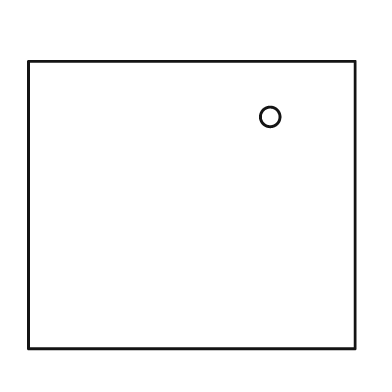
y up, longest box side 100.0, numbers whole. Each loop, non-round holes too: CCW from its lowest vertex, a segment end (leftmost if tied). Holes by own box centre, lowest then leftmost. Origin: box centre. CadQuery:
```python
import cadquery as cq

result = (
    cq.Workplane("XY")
    .moveTo(-50.0, -44.0)
    .lineTo(50.0, -44.0)
    .lineTo(50.0, 44.0)
    .lineTo(-50.0, 44.0)
    .close()
    .moveTo(24.0, 27.0)
    .circle(3.0)
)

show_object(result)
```